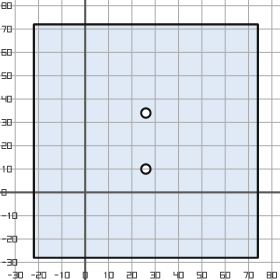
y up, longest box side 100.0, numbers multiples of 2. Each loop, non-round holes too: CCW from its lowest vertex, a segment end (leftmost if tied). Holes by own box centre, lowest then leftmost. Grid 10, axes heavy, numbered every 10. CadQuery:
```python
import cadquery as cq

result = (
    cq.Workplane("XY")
    .moveTo(-22.0, -28.0)
    .lineTo(74.0, -28.0)
    .lineTo(74.0, 72.0)
    .lineTo(-22.0, 72.0)
    .close()
    .moveTo(26.0, 10.0)
    .circle(2.0)
    .moveTo(26.0, 34.0)
    .circle(2.0)
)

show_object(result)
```